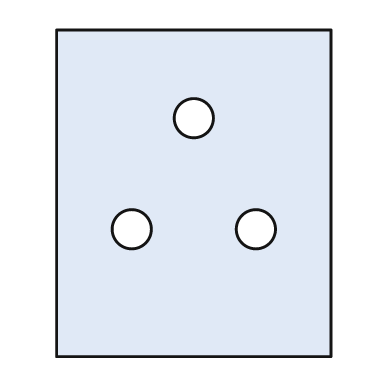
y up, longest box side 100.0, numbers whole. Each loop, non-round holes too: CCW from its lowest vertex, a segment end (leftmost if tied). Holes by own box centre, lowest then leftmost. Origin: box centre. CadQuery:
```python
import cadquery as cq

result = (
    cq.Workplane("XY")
    .moveTo(-42.0, -50.0)
    .lineTo(42.0, -50.0)
    .lineTo(42.0, 50.0)
    .lineTo(-42.0, 50.0)
    .close()
    .moveTo(-19.0, -11.0)
    .circle(6.0)
    .moveTo(19.0, -11.0)
    .circle(6.0)
    .moveTo(0.0, 23.0)
    .circle(6.0)
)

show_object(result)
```